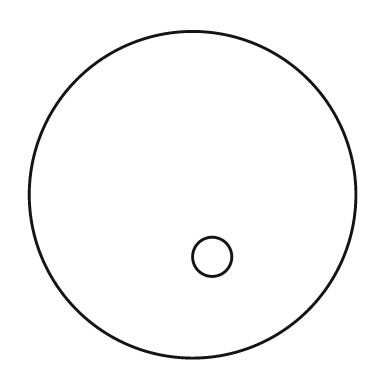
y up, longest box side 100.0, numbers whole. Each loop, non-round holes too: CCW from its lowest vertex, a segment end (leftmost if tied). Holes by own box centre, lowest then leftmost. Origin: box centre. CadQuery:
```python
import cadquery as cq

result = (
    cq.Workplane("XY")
    .moveTo(0.0, 0.0)
    .circle(50.0)
    .moveTo(6.0, -19.0)
    .circle(6.0)
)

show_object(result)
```